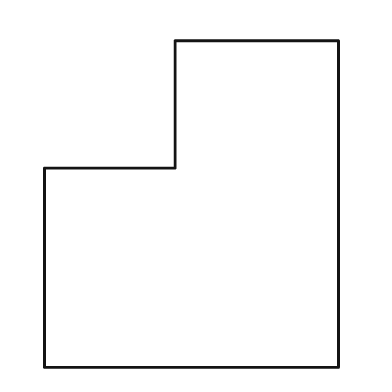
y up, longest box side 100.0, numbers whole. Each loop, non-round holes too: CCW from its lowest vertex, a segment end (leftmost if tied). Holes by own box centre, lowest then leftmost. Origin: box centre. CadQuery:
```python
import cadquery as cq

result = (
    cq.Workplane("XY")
    .moveTo(-45.0, -50.0)
    .lineTo(45.0, -50.0)
    .lineTo(45.0, 50.0)
    .lineTo(-5.0, 50.0)
    .lineTo(-5.0, 11.0)
    .lineTo(-45.0, 11.0)
    .close()
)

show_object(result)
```